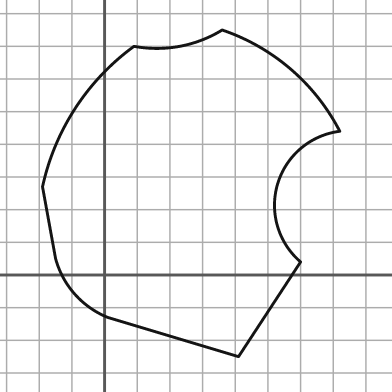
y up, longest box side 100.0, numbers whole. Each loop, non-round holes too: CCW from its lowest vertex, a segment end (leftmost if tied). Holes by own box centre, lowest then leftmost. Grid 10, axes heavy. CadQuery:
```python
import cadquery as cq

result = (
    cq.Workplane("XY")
    .moveTo(41.0, -25.0)
    .lineTo(60.0, 4.0)
    .threePointArc((53.0, 28.0), (72.0, 44.0))
    .threePointArc((57.0, 63.0), (36.0, 75.0))
    .threePointArc((23.0, 70.0), (9.0, 70.0))
    .threePointArc((-9.0, 51.0), (-19.0, 27.0))
    .lineTo(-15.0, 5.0)
    .threePointArc((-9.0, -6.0), (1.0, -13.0))
    .close()
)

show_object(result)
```